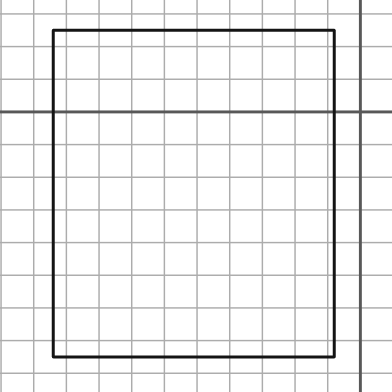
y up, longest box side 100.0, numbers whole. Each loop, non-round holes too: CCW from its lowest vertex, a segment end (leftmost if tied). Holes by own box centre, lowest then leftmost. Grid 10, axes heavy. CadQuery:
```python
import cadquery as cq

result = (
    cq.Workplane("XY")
    .moveTo(-94.0, -75.0)
    .lineTo(-8.0, -75.0)
    .lineTo(-8.0, 25.0)
    .lineTo(-94.0, 25.0)
    .close()
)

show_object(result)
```